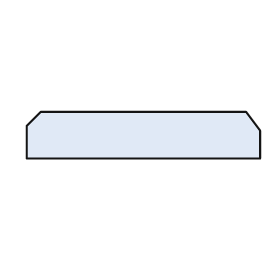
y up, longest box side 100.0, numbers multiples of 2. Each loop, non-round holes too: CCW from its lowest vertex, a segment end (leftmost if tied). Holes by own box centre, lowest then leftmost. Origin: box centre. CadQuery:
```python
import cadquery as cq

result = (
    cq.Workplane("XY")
    .moveTo(-50.0, -10.0)
    .lineTo(50.0, -10.0)
    .lineTo(50.0, 2.0)
    .lineTo(44.0, 10.0)
    .lineTo(-44.0, 10.0)
    .lineTo(-50.0, 4.0)
    .close()
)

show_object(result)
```